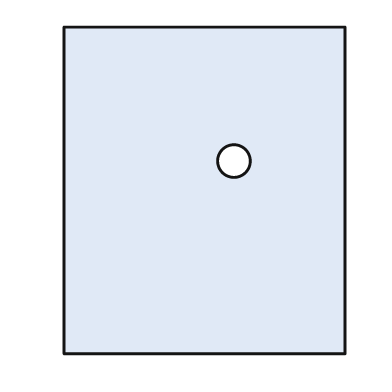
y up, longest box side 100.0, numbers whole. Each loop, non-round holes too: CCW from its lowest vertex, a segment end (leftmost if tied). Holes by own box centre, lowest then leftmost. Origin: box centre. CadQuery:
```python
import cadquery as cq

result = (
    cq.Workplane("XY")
    .moveTo(-43.0, -50.0)
    .lineTo(43.0, -50.0)
    .lineTo(43.0, 50.0)
    .lineTo(-43.0, 50.0)
    .close()
    .moveTo(9.0, 9.0)
    .circle(5.0)
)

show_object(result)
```